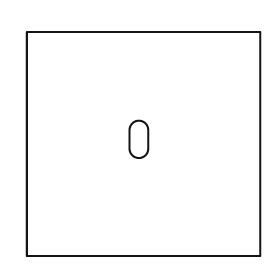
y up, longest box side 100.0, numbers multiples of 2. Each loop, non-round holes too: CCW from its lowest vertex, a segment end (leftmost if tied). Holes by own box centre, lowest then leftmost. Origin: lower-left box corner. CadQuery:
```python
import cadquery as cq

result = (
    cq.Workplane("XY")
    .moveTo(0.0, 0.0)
    .lineTo(100.0, 0.0)
    .lineTo(100.0, 96.0)
    .lineTo(0.0, 96.0)
    .close()
    .moveTo(44.0, 46.0)
    .threePointArc((48.0, 42.0), (52.0, 46.0))
    .lineTo(52.0, 54.0)
    .threePointArc((48.0, 58.0), (44.0, 54.0))
    .close()
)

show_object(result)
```